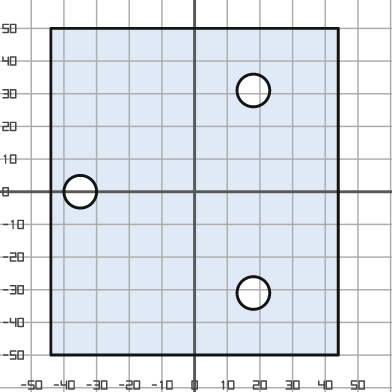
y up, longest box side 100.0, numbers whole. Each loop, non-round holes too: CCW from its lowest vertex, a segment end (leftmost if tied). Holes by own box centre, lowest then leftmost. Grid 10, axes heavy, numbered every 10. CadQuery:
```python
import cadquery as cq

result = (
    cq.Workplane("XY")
    .moveTo(-44.0, -50.0)
    .lineTo(44.0, -50.0)
    .lineTo(44.0, 50.0)
    .lineTo(-44.0, 50.0)
    .close()
    .moveTo(18.0, -31.0)
    .circle(5.0)
    .moveTo(-35.0, 0.0)
    .circle(5.0)
    .moveTo(18.0, 31.0)
    .circle(5.0)
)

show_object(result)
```